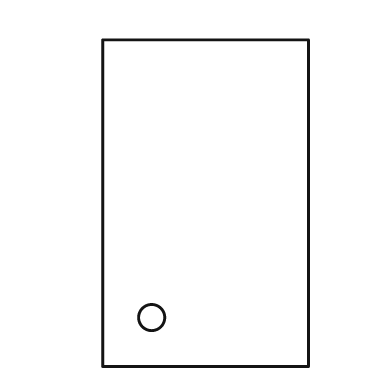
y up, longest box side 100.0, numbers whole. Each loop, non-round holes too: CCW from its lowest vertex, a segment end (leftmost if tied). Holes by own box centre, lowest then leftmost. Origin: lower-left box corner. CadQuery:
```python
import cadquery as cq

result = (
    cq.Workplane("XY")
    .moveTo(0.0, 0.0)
    .lineTo(63.0, 0.0)
    .lineTo(63.0, 100.0)
    .lineTo(0.0, 100.0)
    .close()
    .moveTo(15.0, 15.0)
    .circle(4.0)
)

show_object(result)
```